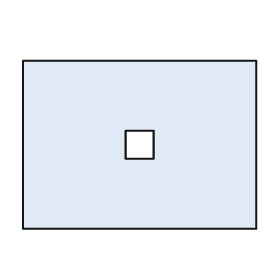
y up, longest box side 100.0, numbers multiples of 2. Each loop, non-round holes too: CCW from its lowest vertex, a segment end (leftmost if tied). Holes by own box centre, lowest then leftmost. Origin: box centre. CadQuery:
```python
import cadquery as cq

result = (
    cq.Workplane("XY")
    .moveTo(-50.0, -36.0)
    .lineTo(50.0, -36.0)
    .lineTo(50.0, 36.0)
    .lineTo(-50.0, 36.0)
    .close()
    .moveTo(-6.0, -6.0)
    .lineTo(6.0, -6.0)
    .lineTo(6.0, 6.0)
    .lineTo(-6.0, 6.0)
    .close()
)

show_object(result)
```